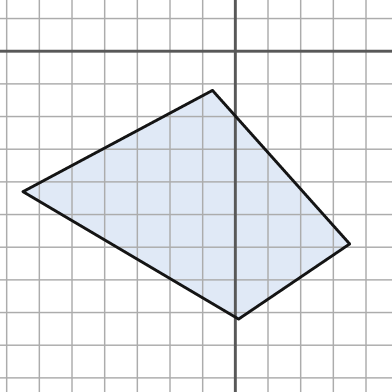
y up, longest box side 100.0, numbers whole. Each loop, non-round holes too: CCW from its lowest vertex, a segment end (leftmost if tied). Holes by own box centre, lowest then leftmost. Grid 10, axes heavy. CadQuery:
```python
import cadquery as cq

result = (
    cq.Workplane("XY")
    .moveTo(1.0, -82.0)
    .lineTo(35.0, -59.0)
    .lineTo(-7.0, -12.0)
    .lineTo(-65.0, -43.0)
    .close()
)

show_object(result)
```